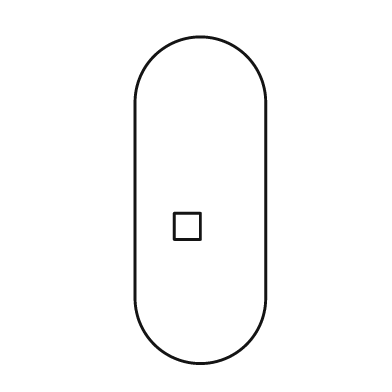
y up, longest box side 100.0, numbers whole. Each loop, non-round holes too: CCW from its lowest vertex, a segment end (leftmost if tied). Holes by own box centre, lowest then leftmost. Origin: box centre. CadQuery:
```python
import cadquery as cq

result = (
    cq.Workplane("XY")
    .moveTo(-20.0, -30.0)
    .threePointArc((0.0, -50.0), (20.0, -30.0))
    .lineTo(20.0, 30.0)
    .threePointArc((0.0, 50.0), (-20.0, 30.0))
    .close()
    .moveTo(-8.0, -12.0)
    .lineTo(0.0, -12.0)
    .lineTo(0.0, -4.0)
    .lineTo(-8.0, -4.0)
    .close()
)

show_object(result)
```